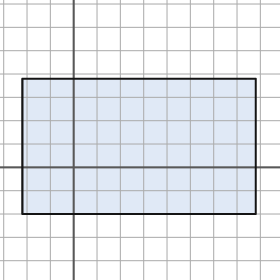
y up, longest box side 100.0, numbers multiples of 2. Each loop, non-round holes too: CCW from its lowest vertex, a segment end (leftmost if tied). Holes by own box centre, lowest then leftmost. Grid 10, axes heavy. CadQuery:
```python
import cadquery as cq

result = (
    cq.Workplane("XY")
    .moveTo(-22.0, -20.0)
    .lineTo(78.0, -20.0)
    .lineTo(78.0, 38.0)
    .lineTo(-22.0, 38.0)
    .close()
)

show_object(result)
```